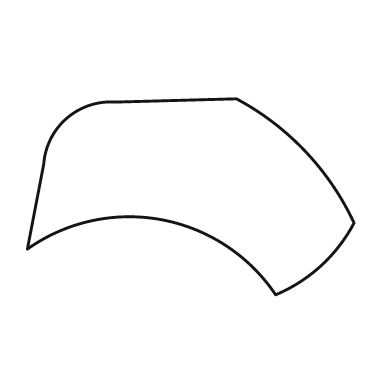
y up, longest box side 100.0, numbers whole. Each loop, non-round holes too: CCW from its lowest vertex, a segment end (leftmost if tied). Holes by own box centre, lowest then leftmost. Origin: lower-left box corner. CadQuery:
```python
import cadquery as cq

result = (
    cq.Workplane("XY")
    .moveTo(76.0, 0.0)
    .threePointArc((90.0, 9.0), (100.0, 22.0))
    .threePointArc((85.0, 44.0), (64.0, 60.0))
    .lineTo(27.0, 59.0)
    .threePointArc((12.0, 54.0), (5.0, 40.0))
    .lineTo(0.0, 14.0)
    .threePointArc((41.0, 23.0), (76.0, 0.0))
    .close()
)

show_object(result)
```